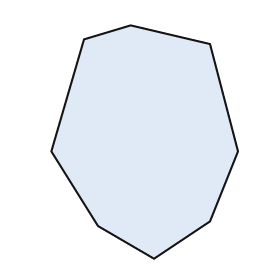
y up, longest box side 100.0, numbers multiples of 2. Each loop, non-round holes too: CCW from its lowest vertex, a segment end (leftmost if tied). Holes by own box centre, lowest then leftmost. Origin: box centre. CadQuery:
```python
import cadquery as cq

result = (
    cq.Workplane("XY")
    .moveTo(4.0, -50.0)
    .lineTo(28.0, -34.0)
    .lineTo(40.0, -4.0)
    .lineTo(28.0, 42.0)
    .lineTo(-6.0, 50.0)
    .lineTo(-26.0, 44.0)
    .lineTo(-40.0, -4.0)
    .lineTo(-20.0, -36.0)
    .close()
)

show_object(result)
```